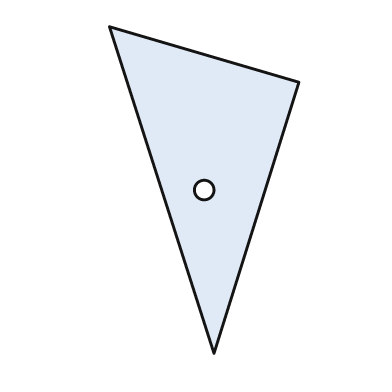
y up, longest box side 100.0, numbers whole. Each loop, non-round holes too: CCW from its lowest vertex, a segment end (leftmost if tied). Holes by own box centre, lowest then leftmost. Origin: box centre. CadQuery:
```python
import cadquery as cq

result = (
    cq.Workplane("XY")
    .moveTo(3.0, -50.0)
    .lineTo(29.0, 33.0)
    .lineTo(-29.0, 50.0)
    .close()
    .moveTo(0.0, 0.0)
    .circle(3.0)
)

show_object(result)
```